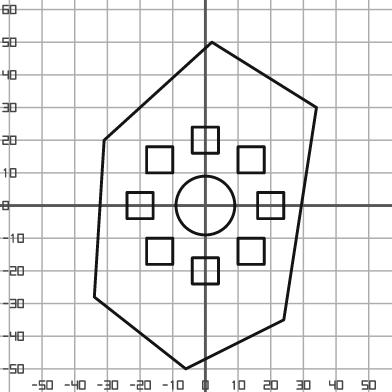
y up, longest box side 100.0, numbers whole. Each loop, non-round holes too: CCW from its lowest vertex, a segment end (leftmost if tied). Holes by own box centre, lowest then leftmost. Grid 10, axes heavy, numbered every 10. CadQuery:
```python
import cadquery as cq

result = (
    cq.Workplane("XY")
    .moveTo(-6.0, -50.0)
    .lineTo(24.0, -35.0)
    .lineTo(34.0, 30.0)
    .lineTo(2.0, 50.0)
    .lineTo(-31.0, 20.0)
    .lineTo(-34.0, -28.0)
    .close()
    .moveTo(-4.0, -24.0)
    .lineTo(4.0, -24.0)
    .lineTo(4.0, -16.0)
    .lineTo(-4.0, -16.0)
    .close()
    .moveTo(-18.0, -18.0)
    .lineTo(-10.0, -18.0)
    .lineTo(-10.0, -10.0)
    .lineTo(-18.0, -10.0)
    .close()
    .moveTo(10.0, -18.0)
    .lineTo(18.0, -18.0)
    .lineTo(18.0, -10.0)
    .lineTo(10.0, -10.0)
    .close()
    .moveTo(-24.0, -4.0)
    .lineTo(-16.0, -4.0)
    .lineTo(-16.0, 4.0)
    .lineTo(-24.0, 4.0)
    .close()
    .moveTo(0.0, 0.0)
    .circle(9.0)
    .moveTo(16.0, -4.0)
    .lineTo(24.0, -4.0)
    .lineTo(24.0, 4.0)
    .lineTo(16.0, 4.0)
    .close()
    .moveTo(-18.0, 10.0)
    .lineTo(-10.0, 10.0)
    .lineTo(-10.0, 18.0)
    .lineTo(-18.0, 18.0)
    .close()
    .moveTo(10.0, 10.0)
    .lineTo(18.0, 10.0)
    .lineTo(18.0, 18.0)
    .lineTo(10.0, 18.0)
    .close()
    .moveTo(-4.0, 16.0)
    .lineTo(4.0, 16.0)
    .lineTo(4.0, 24.0)
    .lineTo(-4.0, 24.0)
    .close()
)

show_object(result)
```